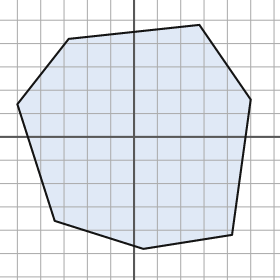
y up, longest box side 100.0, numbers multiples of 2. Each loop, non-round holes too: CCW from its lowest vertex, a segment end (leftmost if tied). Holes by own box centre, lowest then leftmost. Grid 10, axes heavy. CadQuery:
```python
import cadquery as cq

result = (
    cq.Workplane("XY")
    .moveTo(4.0, -48.0)
    .lineTo(42.0, -42.0)
    .lineTo(50.0, 16.0)
    .lineTo(28.0, 48.0)
    .lineTo(-28.0, 42.0)
    .lineTo(-50.0, 14.0)
    .lineTo(-34.0, -36.0)
    .close()
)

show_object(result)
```